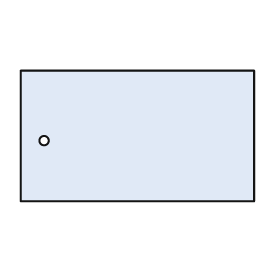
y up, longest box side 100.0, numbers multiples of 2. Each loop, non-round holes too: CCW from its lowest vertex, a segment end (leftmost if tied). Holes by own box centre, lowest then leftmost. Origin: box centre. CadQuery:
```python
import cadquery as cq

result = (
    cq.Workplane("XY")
    .moveTo(-50.0, -28.0)
    .lineTo(50.0, -28.0)
    .lineTo(50.0, 28.0)
    .lineTo(-50.0, 28.0)
    .close()
    .moveTo(-40.0, -2.0)
    .circle(2.0)
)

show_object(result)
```